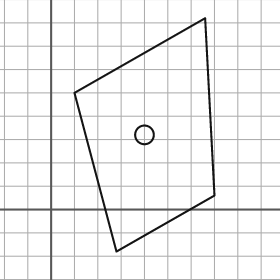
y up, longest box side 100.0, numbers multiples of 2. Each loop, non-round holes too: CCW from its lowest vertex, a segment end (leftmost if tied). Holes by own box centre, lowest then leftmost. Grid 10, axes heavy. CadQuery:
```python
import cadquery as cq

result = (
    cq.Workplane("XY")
    .moveTo(28.0, -18.0)
    .lineTo(70.0, 6.0)
    .lineTo(66.0, 82.0)
    .lineTo(10.0, 50.0)
    .close()
    .moveTo(40.0, 32.0)
    .circle(4.0)
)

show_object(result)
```